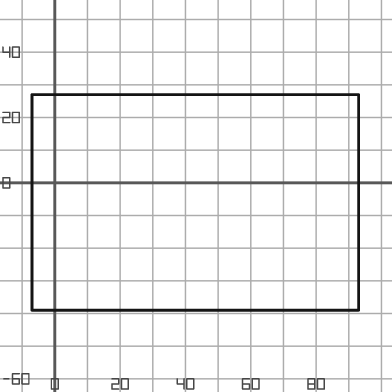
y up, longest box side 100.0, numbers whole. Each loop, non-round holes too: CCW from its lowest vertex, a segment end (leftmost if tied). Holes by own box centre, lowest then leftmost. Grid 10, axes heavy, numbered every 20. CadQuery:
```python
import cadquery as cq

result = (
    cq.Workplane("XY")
    .moveTo(-7.0, -39.0)
    .lineTo(93.0, -39.0)
    .lineTo(93.0, 27.0)
    .lineTo(-7.0, 27.0)
    .close()
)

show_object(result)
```